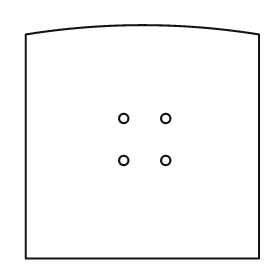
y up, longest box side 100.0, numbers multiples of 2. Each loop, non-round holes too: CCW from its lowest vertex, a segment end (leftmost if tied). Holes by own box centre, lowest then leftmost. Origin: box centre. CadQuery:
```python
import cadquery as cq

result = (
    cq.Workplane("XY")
    .moveTo(-50.0, -50.0)
    .lineTo(50.0, -50.0)
    .lineTo(50.0, 46.0)
    .threePointArc((0.0, 50.0), (-50.0, 46.0))
    .close()
    .moveTo(-8.0, -8.0)
    .circle(2.0)
    .moveTo(10.0, -8.0)
    .circle(2.0)
    .moveTo(-8.0, 10.0)
    .circle(2.0)
    .moveTo(10.0, 10.0)
    .circle(2.0)
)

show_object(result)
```